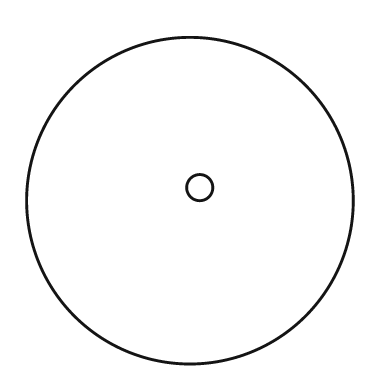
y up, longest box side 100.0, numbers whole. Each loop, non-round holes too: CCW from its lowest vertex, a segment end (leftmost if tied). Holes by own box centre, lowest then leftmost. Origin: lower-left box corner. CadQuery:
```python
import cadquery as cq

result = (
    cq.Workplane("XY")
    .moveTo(50.0, 50.0)
    .circle(50.0)
    .moveTo(53.0, 54.0)
    .circle(4.0)
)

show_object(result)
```